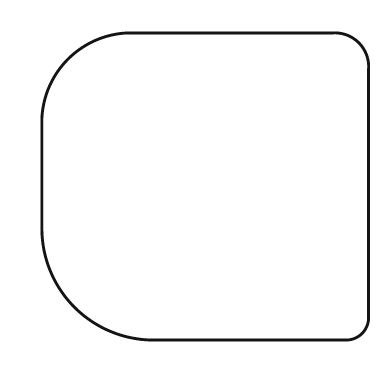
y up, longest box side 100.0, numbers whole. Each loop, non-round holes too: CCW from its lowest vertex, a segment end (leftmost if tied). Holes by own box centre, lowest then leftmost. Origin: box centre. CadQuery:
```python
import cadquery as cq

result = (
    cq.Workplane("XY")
    .moveTo(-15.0, -47.0)
    .lineTo(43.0, -47.0)
    .threePointArc((48.0, -45.0), (50.0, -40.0))
    .lineTo(50.0, 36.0)
    .threePointArc((47.0, 44.0), (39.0, 47.0))
    .lineTo(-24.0, 47.0)
    .threePointArc((-42.0, 39.0), (-50.0, 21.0))
    .lineTo(-50.0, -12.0)
    .threePointArc((-40.0, -37.0), (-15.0, -47.0))
    .close()
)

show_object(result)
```